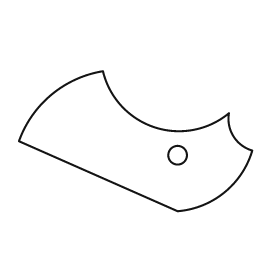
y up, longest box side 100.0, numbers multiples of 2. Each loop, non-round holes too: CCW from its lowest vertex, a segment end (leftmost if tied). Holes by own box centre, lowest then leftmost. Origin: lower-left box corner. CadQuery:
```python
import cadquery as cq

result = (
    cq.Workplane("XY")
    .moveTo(68.0, 0.0)
    .threePointArc((88.0, 8.0), (100.0, 26.0))
    .threePointArc((92.0, 32.0), (90.0, 42.0))
    .threePointArc((58.0, 36.0), (36.0, 60.0))
    .threePointArc((14.0, 50.0), (0.0, 30.0))
    .close()
    .moveTo(68.0, 24.0)
    .circle(4.0)
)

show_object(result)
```